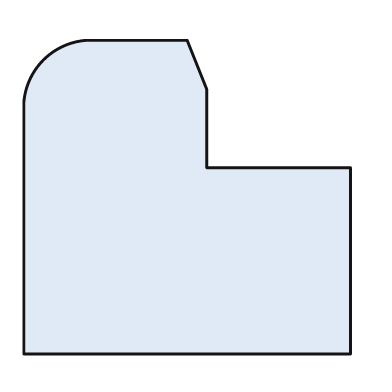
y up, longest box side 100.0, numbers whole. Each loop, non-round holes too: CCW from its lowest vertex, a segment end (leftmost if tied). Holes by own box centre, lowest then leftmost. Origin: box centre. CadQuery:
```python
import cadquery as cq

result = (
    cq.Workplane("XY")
    .moveTo(-50.0, -48.0)
    .lineTo(50.0, -48.0)
    .lineTo(50.0, 9.0)
    .lineTo(6.0, 9.0)
    .lineTo(6.0, 33.0)
    .lineTo(0.0, 48.0)
    .lineTo(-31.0, 48.0)
    .threePointArc((-44.0, 42.0), (-50.0, 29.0))
    .close()
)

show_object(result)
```